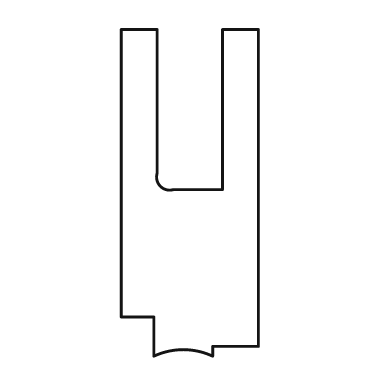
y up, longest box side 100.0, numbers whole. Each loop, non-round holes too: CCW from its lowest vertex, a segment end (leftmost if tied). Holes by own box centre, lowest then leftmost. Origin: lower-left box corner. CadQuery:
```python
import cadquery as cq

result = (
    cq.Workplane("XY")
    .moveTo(10.0, 0.0)
    .threePointArc((19.0, 2.0), (28.0, 0.0))
    .lineTo(28.0, 3.0)
    .lineTo(42.0, 3.0)
    .lineTo(42.0, 100.0)
    .lineTo(31.0, 100.0)
    .lineTo(31.0, 51.0)
    .lineTo(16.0, 51.0)
    .threePointArc((12.0, 52.0), (11.0, 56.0))
    .lineTo(11.0, 100.0)
    .lineTo(0.0, 100.0)
    .lineTo(0.0, 12.0)
    .lineTo(10.0, 12.0)
    .close()
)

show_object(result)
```